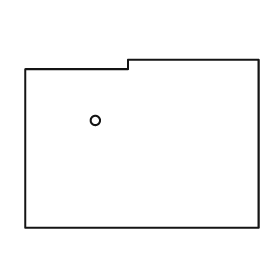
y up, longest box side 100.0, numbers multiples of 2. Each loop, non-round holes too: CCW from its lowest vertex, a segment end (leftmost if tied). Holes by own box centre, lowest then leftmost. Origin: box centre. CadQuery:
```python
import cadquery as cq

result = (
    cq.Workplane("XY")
    .moveTo(-50.0, -36.0)
    .lineTo(50.0, -36.0)
    .lineTo(50.0, 36.0)
    .lineTo(-6.0, 36.0)
    .lineTo(-6.0, 32.0)
    .lineTo(-50.0, 32.0)
    .close()
    .moveTo(-20.0, 10.0)
    .circle(2.0)
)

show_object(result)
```